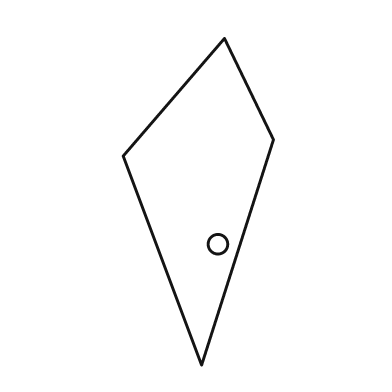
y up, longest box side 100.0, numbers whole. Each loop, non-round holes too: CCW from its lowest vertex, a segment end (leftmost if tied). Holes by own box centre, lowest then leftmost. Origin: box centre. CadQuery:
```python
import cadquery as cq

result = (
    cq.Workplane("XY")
    .moveTo(1.0, -50.0)
    .lineTo(23.0, 19.0)
    .lineTo(8.0, 50.0)
    .lineTo(-23.0, 14.0)
    .close()
    .moveTo(6.0, -13.0)
    .circle(3.0)
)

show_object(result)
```